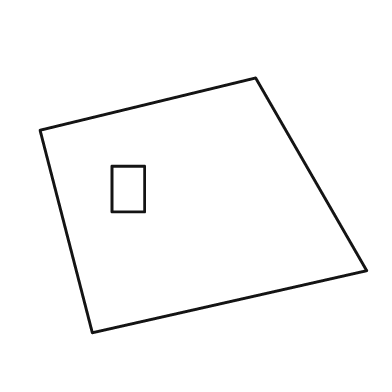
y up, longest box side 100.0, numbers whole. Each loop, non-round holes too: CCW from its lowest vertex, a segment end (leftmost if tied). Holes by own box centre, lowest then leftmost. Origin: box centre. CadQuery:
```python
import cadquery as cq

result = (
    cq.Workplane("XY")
    .moveTo(-34.0, -39.0)
    .lineTo(50.0, -20.0)
    .lineTo(16.0, 39.0)
    .lineTo(-50.0, 23.0)
    .close()
    .moveTo(-28.0, -2.0)
    .lineTo(-18.0, -2.0)
    .lineTo(-18.0, 12.0)
    .lineTo(-28.0, 12.0)
    .close()
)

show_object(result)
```